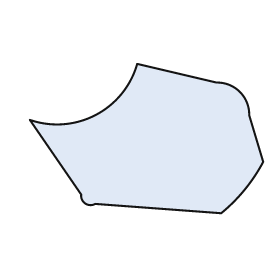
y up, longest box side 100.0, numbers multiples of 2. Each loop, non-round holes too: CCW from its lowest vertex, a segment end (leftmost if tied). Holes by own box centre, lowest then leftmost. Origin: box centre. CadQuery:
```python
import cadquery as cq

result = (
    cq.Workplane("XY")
    .moveTo(32.0, -32.0)
    .threePointArc((42.0, -22.0), (50.0, -10.0))
    .lineTo(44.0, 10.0)
    .threePointArc((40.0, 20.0), (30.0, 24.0))
    .lineTo(-4.0, 32.0)
    .threePointArc((-22.0, 10.0), (-50.0, 8.0))
    .lineTo(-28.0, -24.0)
    .threePointArc((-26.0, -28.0), (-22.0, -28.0))
    .close()
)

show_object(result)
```